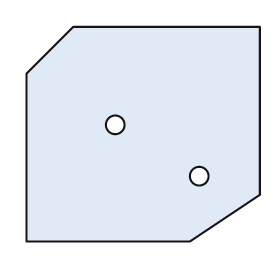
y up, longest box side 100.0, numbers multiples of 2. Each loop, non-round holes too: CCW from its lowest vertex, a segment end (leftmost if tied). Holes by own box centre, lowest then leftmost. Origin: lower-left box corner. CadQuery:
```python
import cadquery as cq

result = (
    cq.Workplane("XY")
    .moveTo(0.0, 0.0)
    .lineTo(70.0, 0.0)
    .lineTo(100.0, 20.0)
    .lineTo(100.0, 92.0)
    .lineTo(20.0, 92.0)
    .lineTo(0.0, 72.0)
    .close()
    .moveTo(74.0, 28.0)
    .circle(4.0)
    .moveTo(38.0, 50.0)
    .circle(4.0)
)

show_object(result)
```